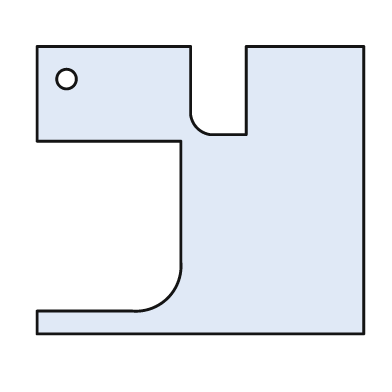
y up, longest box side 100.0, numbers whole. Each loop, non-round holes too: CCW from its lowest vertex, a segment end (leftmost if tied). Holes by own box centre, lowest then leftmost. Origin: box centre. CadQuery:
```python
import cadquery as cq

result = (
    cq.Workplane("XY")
    .moveTo(-50.0, -44.0)
    .lineTo(50.0, -44.0)
    .lineTo(50.0, 44.0)
    .lineTo(14.0, 44.0)
    .lineTo(14.0, 17.0)
    .lineTo(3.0, 17.0)
    .threePointArc((-1.0, 19.0), (-3.0, 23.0))
    .lineTo(-3.0, 44.0)
    .lineTo(-50.0, 44.0)
    .lineTo(-50.0, 15.0)
    .lineTo(-6.0, 15.0)
    .lineTo(-6.0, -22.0)
    .threePointArc((-10.0, -33.0), (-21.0, -37.0))
    .lineTo(-50.0, -37.0)
    .close()
    .moveTo(-41.0, 34.0)
    .circle(3.0)
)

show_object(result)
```